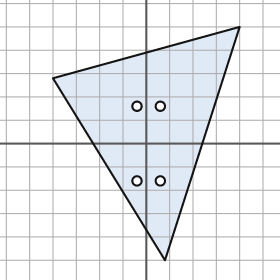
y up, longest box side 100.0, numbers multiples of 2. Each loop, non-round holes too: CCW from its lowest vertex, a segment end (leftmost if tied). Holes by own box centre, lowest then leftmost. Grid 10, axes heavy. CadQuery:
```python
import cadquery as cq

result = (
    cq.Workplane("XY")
    .moveTo(8.0, -50.0)
    .lineTo(40.0, 50.0)
    .lineTo(-40.0, 28.0)
    .close()
    .moveTo(-4.0, -16.0)
    .circle(2.0)
    .moveTo(6.0, -16.0)
    .circle(2.0)
    .moveTo(-4.0, 16.0)
    .circle(2.0)
    .moveTo(6.0, 16.0)
    .circle(2.0)
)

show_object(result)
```